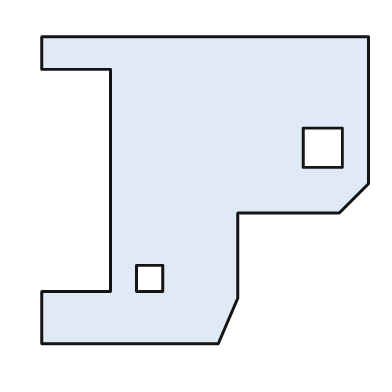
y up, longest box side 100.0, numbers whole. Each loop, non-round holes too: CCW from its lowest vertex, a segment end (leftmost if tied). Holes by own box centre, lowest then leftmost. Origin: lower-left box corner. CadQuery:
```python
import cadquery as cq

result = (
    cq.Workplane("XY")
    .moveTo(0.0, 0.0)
    .lineTo(54.0, 0.0)
    .lineTo(60.0, 14.0)
    .lineTo(60.0, 40.0)
    .lineTo(91.0, 40.0)
    .lineTo(100.0, 49.0)
    .lineTo(100.0, 94.0)
    .lineTo(0.0, 94.0)
    .lineTo(0.0, 84.0)
    .lineTo(21.0, 84.0)
    .lineTo(21.0, 16.0)
    .lineTo(0.0, 16.0)
    .close()
    .moveTo(29.0, 16.0)
    .lineTo(37.0, 16.0)
    .lineTo(37.0, 24.0)
    .lineTo(29.0, 24.0)
    .close()
    .moveTo(80.0, 54.0)
    .lineTo(92.0, 54.0)
    .lineTo(92.0, 66.0)
    .lineTo(80.0, 66.0)
    .close()
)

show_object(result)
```